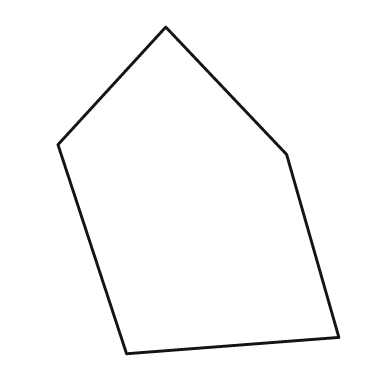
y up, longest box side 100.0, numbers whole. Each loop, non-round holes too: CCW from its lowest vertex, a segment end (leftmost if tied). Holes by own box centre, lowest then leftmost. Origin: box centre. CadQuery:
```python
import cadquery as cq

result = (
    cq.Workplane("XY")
    .moveTo(-22.0, -50.0)
    .lineTo(43.0, -45.0)
    .lineTo(27.0, 11.0)
    .lineTo(-10.0, 50.0)
    .lineTo(-43.0, 14.0)
    .close()
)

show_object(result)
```